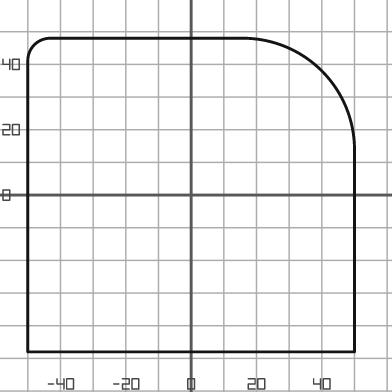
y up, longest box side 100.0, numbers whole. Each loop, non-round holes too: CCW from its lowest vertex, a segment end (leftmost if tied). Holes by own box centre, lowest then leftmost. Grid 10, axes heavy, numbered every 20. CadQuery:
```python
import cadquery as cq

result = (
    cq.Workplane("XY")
    .moveTo(-50.0, -48.0)
    .lineTo(50.0, -48.0)
    .lineTo(50.0, 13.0)
    .threePointArc((40.0, 38.0), (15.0, 48.0))
    .lineTo(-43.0, 48.0)
    .threePointArc((-48.0, 46.0), (-50.0, 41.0))
    .close()
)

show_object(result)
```